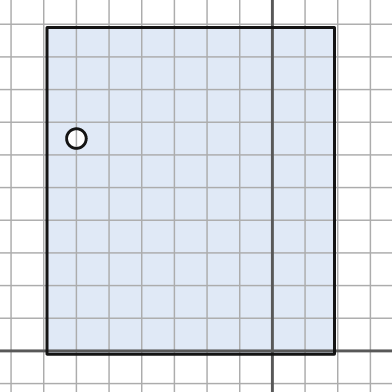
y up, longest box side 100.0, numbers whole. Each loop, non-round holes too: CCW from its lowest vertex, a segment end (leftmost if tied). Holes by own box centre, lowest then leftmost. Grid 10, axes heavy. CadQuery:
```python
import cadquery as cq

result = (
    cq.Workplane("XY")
    .moveTo(-69.0, -1.0)
    .lineTo(19.0, -1.0)
    .lineTo(19.0, 99.0)
    .lineTo(-69.0, 99.0)
    .close()
    .moveTo(-60.0, 65.0)
    .circle(3.0)
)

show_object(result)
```